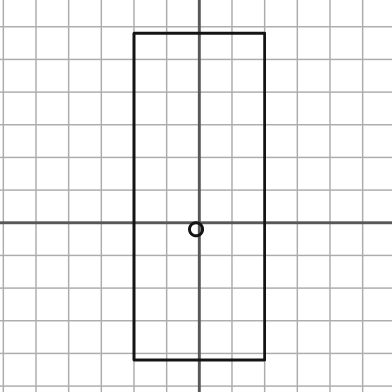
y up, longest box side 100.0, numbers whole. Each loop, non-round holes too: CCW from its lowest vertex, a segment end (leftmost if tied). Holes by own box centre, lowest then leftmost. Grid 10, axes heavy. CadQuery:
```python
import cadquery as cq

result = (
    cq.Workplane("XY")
    .moveTo(-20.0, -42.0)
    .lineTo(20.0, -42.0)
    .lineTo(20.0, 58.0)
    .lineTo(-20.0, 58.0)
    .close()
    .moveTo(-1.0, -2.0)
    .circle(2.0)
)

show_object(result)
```